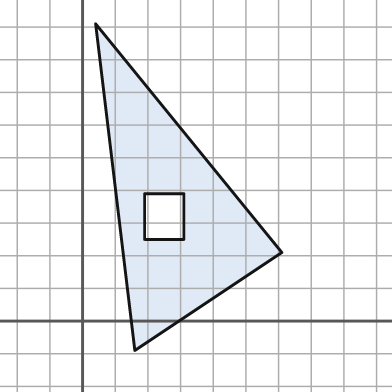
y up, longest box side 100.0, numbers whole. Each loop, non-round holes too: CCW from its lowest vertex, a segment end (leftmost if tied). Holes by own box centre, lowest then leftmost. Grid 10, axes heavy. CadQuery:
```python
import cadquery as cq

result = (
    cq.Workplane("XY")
    .moveTo(16.0, -9.0)
    .lineTo(61.0, 21.0)
    .lineTo(4.0, 91.0)
    .close()
    .moveTo(19.0, 25.0)
    .lineTo(31.0, 25.0)
    .lineTo(31.0, 39.0)
    .lineTo(19.0, 39.0)
    .close()
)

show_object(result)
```